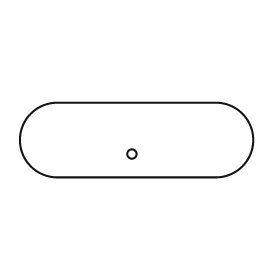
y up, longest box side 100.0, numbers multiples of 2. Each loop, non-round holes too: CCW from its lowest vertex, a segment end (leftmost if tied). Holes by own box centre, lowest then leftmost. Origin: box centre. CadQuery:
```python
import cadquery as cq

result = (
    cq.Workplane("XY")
    .moveTo(-34.0, -16.0)
    .lineTo(34.0, -16.0)
    .threePointArc((50.0, 0.0), (34.0, 16.0))
    .lineTo(-34.0, 16.0)
    .threePointArc((-50.0, 0.0), (-34.0, -16.0))
    .close()
    .moveTo(-2.0, -6.0)
    .circle(2.0)
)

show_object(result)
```